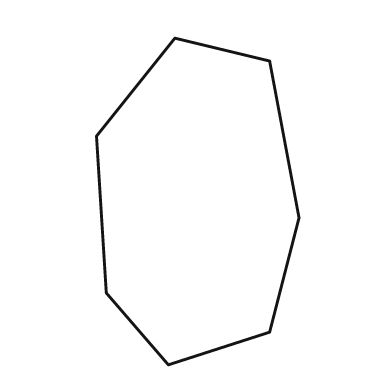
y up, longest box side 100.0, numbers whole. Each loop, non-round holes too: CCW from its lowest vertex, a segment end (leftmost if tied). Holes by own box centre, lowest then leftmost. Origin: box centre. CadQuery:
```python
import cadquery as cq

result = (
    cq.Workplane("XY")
    .moveTo(-9.0, -50.0)
    .lineTo(22.0, -40.0)
    .lineTo(31.0, -5.0)
    .lineTo(22.0, 43.0)
    .lineTo(-7.0, 50.0)
    .lineTo(-31.0, 20.0)
    .lineTo(-28.0, -28.0)
    .close()
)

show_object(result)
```